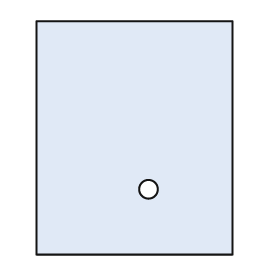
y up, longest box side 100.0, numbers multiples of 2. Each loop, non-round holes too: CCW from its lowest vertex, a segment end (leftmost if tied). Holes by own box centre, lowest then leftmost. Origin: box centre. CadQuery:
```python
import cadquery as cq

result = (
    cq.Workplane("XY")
    .moveTo(-42.0, -50.0)
    .lineTo(42.0, -50.0)
    .lineTo(42.0, 50.0)
    .lineTo(-42.0, 50.0)
    .close()
    .moveTo(6.0, -22.0)
    .circle(4.0)
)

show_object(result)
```